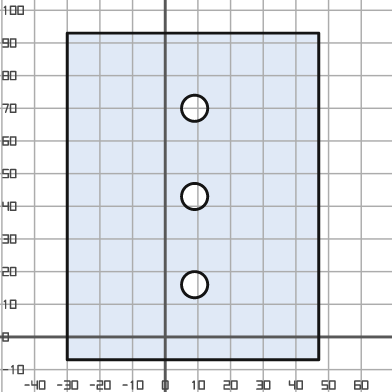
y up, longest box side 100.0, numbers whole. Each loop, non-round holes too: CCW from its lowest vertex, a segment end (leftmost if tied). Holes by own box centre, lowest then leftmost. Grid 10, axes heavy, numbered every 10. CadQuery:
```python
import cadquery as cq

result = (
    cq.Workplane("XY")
    .moveTo(-30.0, -7.0)
    .lineTo(47.0, -7.0)
    .lineTo(47.0, 93.0)
    .lineTo(-30.0, 93.0)
    .close()
    .moveTo(9.0, 16.0)
    .circle(4.0)
    .moveTo(9.0, 43.0)
    .circle(4.0)
    .moveTo(9.0, 70.0)
    .circle(4.0)
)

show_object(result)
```